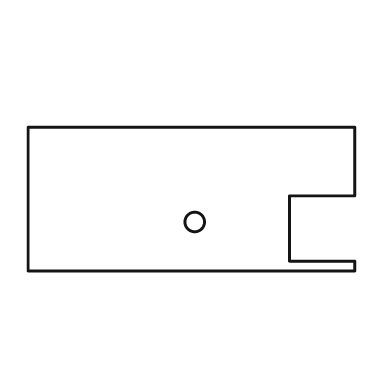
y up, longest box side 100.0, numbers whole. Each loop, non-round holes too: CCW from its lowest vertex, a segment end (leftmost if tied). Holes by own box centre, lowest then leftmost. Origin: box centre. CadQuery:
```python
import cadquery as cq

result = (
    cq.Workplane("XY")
    .moveTo(-50.0, -22.0)
    .lineTo(50.0, -22.0)
    .lineTo(50.0, -19.0)
    .lineTo(30.0, -19.0)
    .lineTo(30.0, 1.0)
    .lineTo(50.0, 1.0)
    .lineTo(50.0, 22.0)
    .lineTo(-50.0, 22.0)
    .close()
    .moveTo(1.0, -7.0)
    .circle(3.0)
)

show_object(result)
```